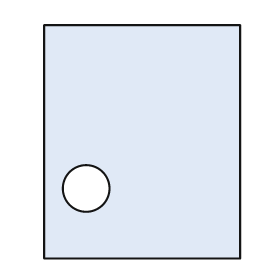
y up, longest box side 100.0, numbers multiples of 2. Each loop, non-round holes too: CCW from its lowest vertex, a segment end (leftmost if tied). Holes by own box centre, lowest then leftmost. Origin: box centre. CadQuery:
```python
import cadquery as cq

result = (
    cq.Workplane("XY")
    .moveTo(-42.0, -50.0)
    .lineTo(42.0, -50.0)
    .lineTo(42.0, 50.0)
    .lineTo(-42.0, 50.0)
    .close()
    .moveTo(-24.0, -20.0)
    .circle(10.0)
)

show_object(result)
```